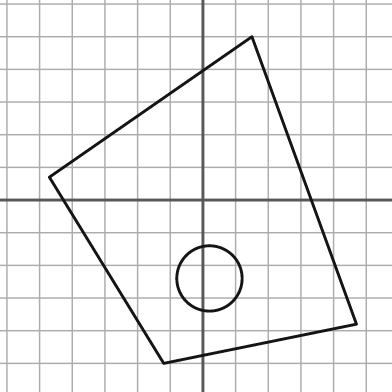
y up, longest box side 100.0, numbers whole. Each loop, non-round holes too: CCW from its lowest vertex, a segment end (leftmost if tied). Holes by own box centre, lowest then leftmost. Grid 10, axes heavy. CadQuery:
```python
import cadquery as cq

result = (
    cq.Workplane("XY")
    .moveTo(-12.0, -50.0)
    .lineTo(47.0, -38.0)
    .lineTo(15.0, 50.0)
    .lineTo(-47.0, 7.0)
    .close()
    .moveTo(2.0, -24.0)
    .circle(10.0)
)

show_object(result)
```